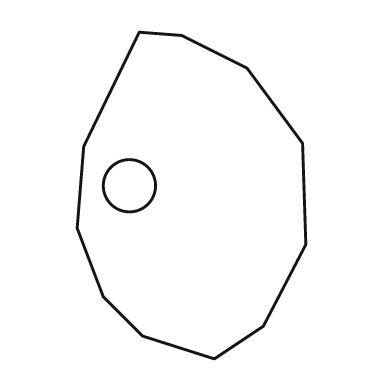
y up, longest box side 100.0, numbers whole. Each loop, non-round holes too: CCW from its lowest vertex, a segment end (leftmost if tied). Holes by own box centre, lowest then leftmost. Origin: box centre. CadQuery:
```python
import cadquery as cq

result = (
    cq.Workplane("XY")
    .moveTo(7.0, -50.0)
    .lineTo(22.0, -40.0)
    .lineTo(35.0, -15.0)
    .lineTo(34.0, 16.0)
    .lineTo(17.0, 39.0)
    .lineTo(-3.0, 49.0)
    .lineTo(-16.0, 50.0)
    .lineTo(-33.0, 15.0)
    .lineTo(-35.0, -10.0)
    .lineTo(-27.0, -31.0)
    .lineTo(-15.0, -43.0)
    .close()
    .moveTo(-19.0, 3.0)
    .circle(8.0)
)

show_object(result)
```